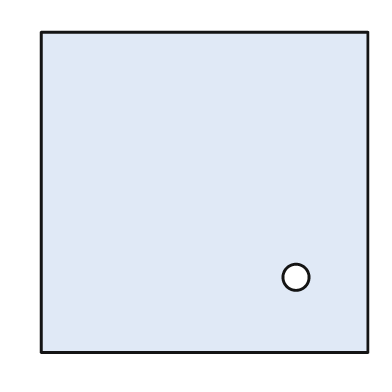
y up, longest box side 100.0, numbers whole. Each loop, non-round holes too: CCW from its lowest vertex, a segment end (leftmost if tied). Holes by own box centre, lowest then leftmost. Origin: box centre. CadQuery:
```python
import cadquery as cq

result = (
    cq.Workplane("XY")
    .moveTo(-50.0, -49.0)
    .lineTo(50.0, -49.0)
    .lineTo(50.0, 49.0)
    .lineTo(-50.0, 49.0)
    .close()
    .moveTo(28.0, -26.0)
    .circle(4.0)
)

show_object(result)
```